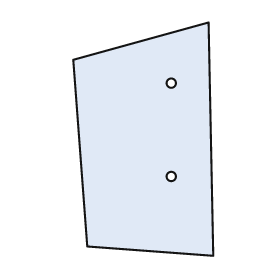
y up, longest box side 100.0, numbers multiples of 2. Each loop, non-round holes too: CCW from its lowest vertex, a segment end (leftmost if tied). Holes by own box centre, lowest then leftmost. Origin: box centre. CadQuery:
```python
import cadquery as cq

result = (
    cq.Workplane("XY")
    .moveTo(30.0, -50.0)
    .lineTo(28.0, 50.0)
    .lineTo(-30.0, 34.0)
    .lineTo(-24.0, -46.0)
    .close()
    .moveTo(12.0, -16.0)
    .circle(2.0)
    .moveTo(12.0, 24.0)
    .circle(2.0)
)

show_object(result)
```